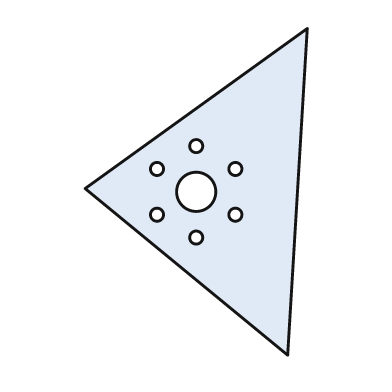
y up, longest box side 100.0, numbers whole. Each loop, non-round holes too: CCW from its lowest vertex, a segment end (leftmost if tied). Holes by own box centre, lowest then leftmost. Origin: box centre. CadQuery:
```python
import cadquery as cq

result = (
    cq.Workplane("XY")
    .moveTo(28.0, -50.0)
    .lineTo(34.0, 50.0)
    .lineTo(-34.0, 1.0)
    .close()
    .moveTo(0.0, -14.0)
    .circle(2.0)
    .moveTo(-12.0, -7.0)
    .circle(2.0)
    .moveTo(12.0, -7.0)
    .circle(2.0)
    .moveTo(0.0, 0.0)
    .circle(6.0)
    .moveTo(-12.0, 7.0)
    .circle(2.0)
    .moveTo(12.0, 7.0)
    .circle(2.0)
    .moveTo(0.0, 14.0)
    .circle(2.0)
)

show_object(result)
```